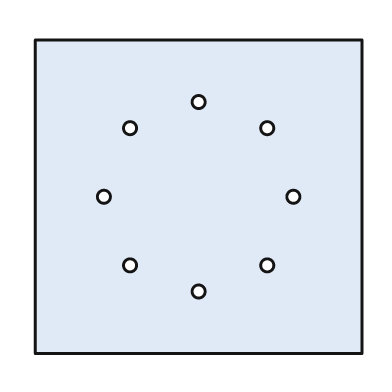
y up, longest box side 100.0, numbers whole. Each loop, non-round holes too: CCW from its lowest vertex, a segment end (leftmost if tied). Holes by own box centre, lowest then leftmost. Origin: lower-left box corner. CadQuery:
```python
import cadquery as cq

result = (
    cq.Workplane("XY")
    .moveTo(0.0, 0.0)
    .lineTo(100.0, 0.0)
    .lineTo(100.0, 96.0)
    .lineTo(0.0, 96.0)
    .close()
    .moveTo(50.0, 19.0)
    .circle(2.0)
    .moveTo(29.0, 27.0)
    .circle(2.0)
    .moveTo(71.0, 27.0)
    .circle(2.0)
    .moveTo(21.0, 48.0)
    .circle(2.0)
    .moveTo(79.0, 48.0)
    .circle(2.0)
    .moveTo(29.0, 69.0)
    .circle(2.0)
    .moveTo(71.0, 69.0)
    .circle(2.0)
    .moveTo(50.0, 77.0)
    .circle(2.0)
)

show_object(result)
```